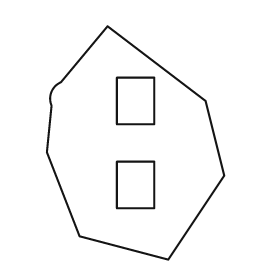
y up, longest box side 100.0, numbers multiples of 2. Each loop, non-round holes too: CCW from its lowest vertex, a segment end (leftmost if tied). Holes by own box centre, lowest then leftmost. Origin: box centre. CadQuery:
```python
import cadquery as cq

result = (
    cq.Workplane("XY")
    .moveTo(14.0, -50.0)
    .lineTo(38.0, -14.0)
    .lineTo(30.0, 18.0)
    .lineTo(-12.0, 50.0)
    .lineTo(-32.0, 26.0)
    .threePointArc((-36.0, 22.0), (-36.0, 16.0))
    .lineTo(-38.0, -4.0)
    .lineTo(-24.0, -40.0)
    .close()
    .moveTo(-8.0, -28.0)
    .lineTo(8.0, -28.0)
    .lineTo(8.0, -8.0)
    .lineTo(-8.0, -8.0)
    .close()
    .moveTo(-8.0, 8.0)
    .lineTo(8.0, 8.0)
    .lineTo(8.0, 28.0)
    .lineTo(-8.0, 28.0)
    .close()
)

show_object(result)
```